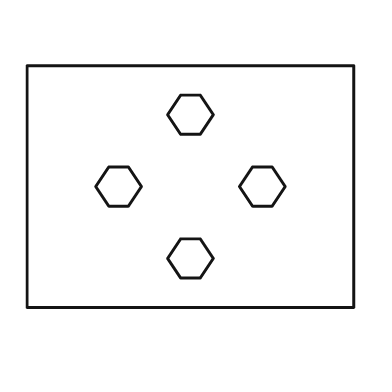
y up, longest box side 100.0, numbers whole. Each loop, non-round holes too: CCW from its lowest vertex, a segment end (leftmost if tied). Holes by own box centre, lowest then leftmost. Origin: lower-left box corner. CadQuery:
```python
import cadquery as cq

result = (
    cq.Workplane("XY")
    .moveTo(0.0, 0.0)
    .lineTo(100.0, 0.0)
    .lineTo(100.0, 74.0)
    .lineTo(0.0, 74.0)
    .close()
    .moveTo(47.0, 9.0)
    .lineTo(53.0, 9.0)
    .lineTo(57.0, 15.0)
    .lineTo(53.0, 21.0)
    .lineTo(47.0, 21.0)
    .lineTo(43.0, 15.0)
    .close()
    .moveTo(25.0, 31.0)
    .lineTo(31.0, 31.0)
    .lineTo(35.0, 37.0)
    .lineTo(31.0, 43.0)
    .lineTo(25.0, 43.0)
    .lineTo(21.0, 37.0)
    .close()
    .moveTo(69.0, 31.0)
    .lineTo(75.0, 31.0)
    .lineTo(79.0, 37.0)
    .lineTo(75.0, 43.0)
    .lineTo(69.0, 43.0)
    .lineTo(65.0, 37.0)
    .close()
    .moveTo(47.0, 53.0)
    .lineTo(53.0, 53.0)
    .lineTo(57.0, 59.0)
    .lineTo(53.0, 65.0)
    .lineTo(47.0, 65.0)
    .lineTo(43.0, 59.0)
    .close()
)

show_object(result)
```